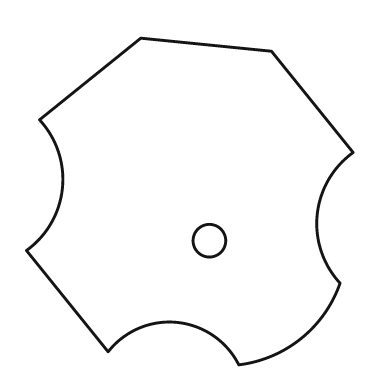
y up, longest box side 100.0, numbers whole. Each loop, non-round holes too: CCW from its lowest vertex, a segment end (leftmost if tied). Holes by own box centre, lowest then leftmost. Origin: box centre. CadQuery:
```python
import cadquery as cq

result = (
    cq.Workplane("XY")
    .moveTo(15.0, -50.0)
    .threePointArc((34.0, -42.0), (46.0, -25.0))
    .threePointArc((39.0, -4.0), (50.0, 15.0))
    .lineTo(25.0, 46.0)
    .lineTo(-15.0, 50.0)
    .lineTo(-46.0, 25.0)
    .threePointArc((-39.0, 4.0), (-50.0, -15.0))
    .lineTo(-25.0, -46.0)
    .threePointArc((-4.0, -37.0), (15.0, -50.0))
    .close()
    .moveTo(6.0, -12.0)
    .circle(5.0)
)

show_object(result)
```